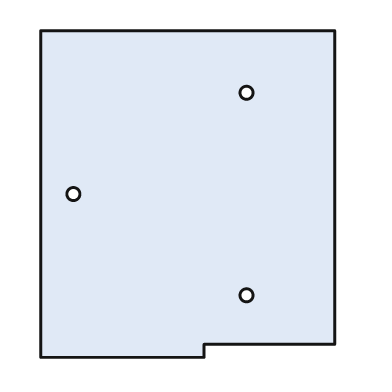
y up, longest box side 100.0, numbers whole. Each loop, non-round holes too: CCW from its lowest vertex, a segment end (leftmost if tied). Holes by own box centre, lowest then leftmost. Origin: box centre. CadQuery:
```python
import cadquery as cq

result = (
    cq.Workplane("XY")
    .moveTo(-45.0, -50.0)
    .lineTo(5.0, -50.0)
    .lineTo(5.0, -46.0)
    .lineTo(45.0, -46.0)
    .lineTo(45.0, 50.0)
    .lineTo(-45.0, 50.0)
    .close()
    .moveTo(18.0, -31.0)
    .circle(2.0)
    .moveTo(-35.0, 0.0)
    .circle(2.0)
    .moveTo(18.0, 31.0)
    .circle(2.0)
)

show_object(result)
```